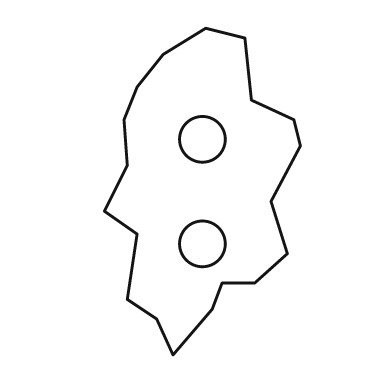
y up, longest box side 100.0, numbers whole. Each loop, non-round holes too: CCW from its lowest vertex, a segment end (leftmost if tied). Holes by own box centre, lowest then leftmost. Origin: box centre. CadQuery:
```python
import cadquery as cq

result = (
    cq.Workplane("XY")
    .moveTo(-9.0, -50.0)
    .lineTo(3.0, -36.0)
    .lineTo(6.0, -28.0)
    .lineTo(16.0, -28.0)
    .lineTo(26.0, -19.0)
    .lineTo(21.0, -3.0)
    .lineTo(30.0, 14.0)
    .lineTo(28.0, 22.0)
    .lineTo(15.0, 28.0)
    .lineTo(13.0, 47.0)
    .lineTo(1.0, 50.0)
    .lineTo(-12.0, 42.0)
    .lineTo(-20.0, 32.0)
    .lineTo(-24.0, 22.0)
    .lineTo(-23.0, 8.0)
    .lineTo(-30.0, -6.0)
    .lineTo(-20.0, -13.0)
    .lineTo(-23.0, -33.0)
    .lineTo(-14.0, -39.0)
    .close()
    .moveTo(0.0, -16.0)
    .circle(7.0)
    .moveTo(0.0, 16.0)
    .circle(7.0)
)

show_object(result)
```